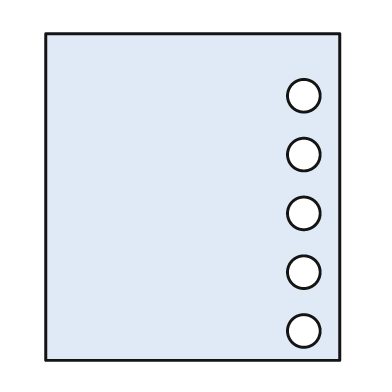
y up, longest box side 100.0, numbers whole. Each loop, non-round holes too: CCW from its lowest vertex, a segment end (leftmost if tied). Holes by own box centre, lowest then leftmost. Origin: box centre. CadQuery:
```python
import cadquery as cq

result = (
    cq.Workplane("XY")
    .moveTo(-45.0, -50.0)
    .lineTo(45.0, -50.0)
    .lineTo(45.0, 50.0)
    .lineTo(-45.0, 50.0)
    .close()
    .moveTo(34.0, -41.0)
    .circle(5.0)
    .moveTo(34.0, -23.0)
    .circle(5.0)
    .moveTo(34.0, -5.0)
    .circle(5.0)
    .moveTo(34.0, 13.0)
    .circle(5.0)
    .moveTo(34.0, 31.0)
    .circle(5.0)
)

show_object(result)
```